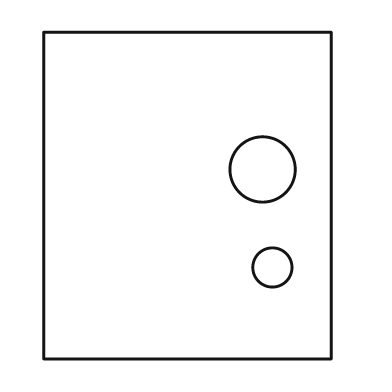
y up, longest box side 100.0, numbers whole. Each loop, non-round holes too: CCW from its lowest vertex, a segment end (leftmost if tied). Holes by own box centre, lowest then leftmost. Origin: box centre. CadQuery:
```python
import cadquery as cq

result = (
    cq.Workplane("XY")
    .moveTo(-44.0, -50.0)
    .lineTo(44.0, -50.0)
    .lineTo(44.0, 50.0)
    .lineTo(-44.0, 50.0)
    .close()
    .moveTo(26.0, -22.0)
    .circle(6.0)
    .moveTo(23.0, 8.0)
    .circle(10.0)
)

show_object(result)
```